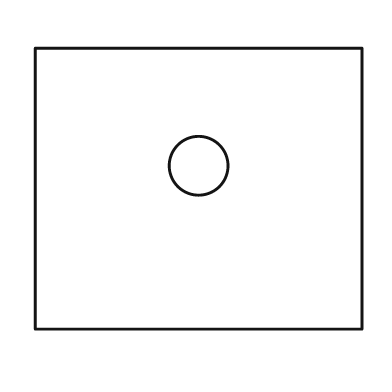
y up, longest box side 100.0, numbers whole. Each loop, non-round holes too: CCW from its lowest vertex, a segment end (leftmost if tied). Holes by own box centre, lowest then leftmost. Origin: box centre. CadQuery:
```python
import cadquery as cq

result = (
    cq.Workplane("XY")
    .moveTo(-50.0, -43.0)
    .lineTo(50.0, -43.0)
    .lineTo(50.0, 43.0)
    .lineTo(-50.0, 43.0)
    .close()
    .moveTo(0.0, 7.0)
    .circle(9.0)
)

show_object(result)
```